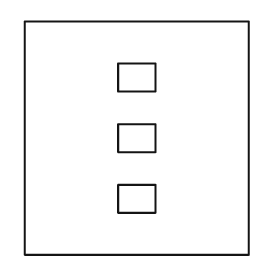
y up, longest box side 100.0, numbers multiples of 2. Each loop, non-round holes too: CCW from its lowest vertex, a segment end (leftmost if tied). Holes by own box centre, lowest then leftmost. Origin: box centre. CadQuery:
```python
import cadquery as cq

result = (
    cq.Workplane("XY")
    .moveTo(-48.0, -50.0)
    .lineTo(48.0, -50.0)
    .lineTo(48.0, 50.0)
    .lineTo(-48.0, 50.0)
    .close()
    .moveTo(-8.0, -32.0)
    .lineTo(8.0, -32.0)
    .lineTo(8.0, -20.0)
    .lineTo(-8.0, -20.0)
    .close()
    .moveTo(-8.0, -6.0)
    .lineTo(8.0, -6.0)
    .lineTo(8.0, 6.0)
    .lineTo(-8.0, 6.0)
    .close()
    .moveTo(-8.0, 20.0)
    .lineTo(8.0, 20.0)
    .lineTo(8.0, 32.0)
    .lineTo(-8.0, 32.0)
    .close()
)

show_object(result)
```